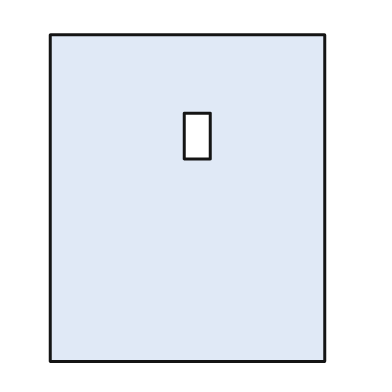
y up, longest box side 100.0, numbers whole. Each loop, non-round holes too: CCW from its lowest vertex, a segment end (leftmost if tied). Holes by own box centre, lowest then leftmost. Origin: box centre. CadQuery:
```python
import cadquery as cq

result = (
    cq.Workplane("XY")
    .moveTo(-42.0, -50.0)
    .lineTo(42.0, -50.0)
    .lineTo(42.0, 50.0)
    .lineTo(-42.0, 50.0)
    .close()
    .moveTo(-1.0, 12.0)
    .lineTo(7.0, 12.0)
    .lineTo(7.0, 26.0)
    .lineTo(-1.0, 26.0)
    .close()
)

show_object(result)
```